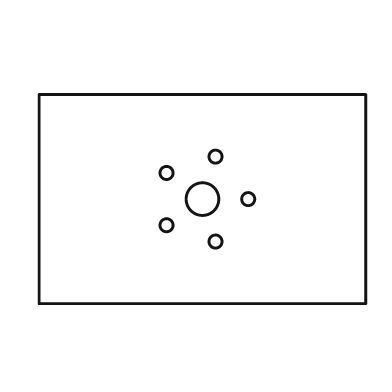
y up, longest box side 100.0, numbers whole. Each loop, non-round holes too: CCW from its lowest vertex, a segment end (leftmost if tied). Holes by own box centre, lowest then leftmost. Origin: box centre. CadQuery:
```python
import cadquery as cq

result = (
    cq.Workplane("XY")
    .moveTo(-50.0, -32.0)
    .lineTo(50.0, -32.0)
    .lineTo(50.0, 32.0)
    .lineTo(-50.0, 32.0)
    .close()
    .moveTo(4.0, -13.0)
    .circle(2.0)
    .moveTo(-11.0, -8.0)
    .circle(2.0)
    .moveTo(0.0, 0.0)
    .circle(5.0)
    .moveTo(14.0, 0.0)
    .circle(2.0)
    .moveTo(-11.0, 8.0)
    .circle(2.0)
    .moveTo(4.0, 13.0)
    .circle(2.0)
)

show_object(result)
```